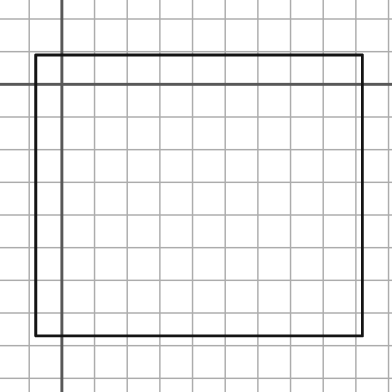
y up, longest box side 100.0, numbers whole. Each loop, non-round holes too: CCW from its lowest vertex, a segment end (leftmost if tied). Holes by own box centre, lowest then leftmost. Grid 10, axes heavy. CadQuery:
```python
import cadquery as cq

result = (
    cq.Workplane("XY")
    .moveTo(-8.0, -77.0)
    .lineTo(92.0, -77.0)
    .lineTo(92.0, 9.0)
    .lineTo(-8.0, 9.0)
    .close()
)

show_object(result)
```